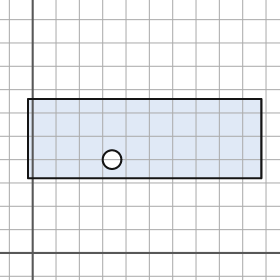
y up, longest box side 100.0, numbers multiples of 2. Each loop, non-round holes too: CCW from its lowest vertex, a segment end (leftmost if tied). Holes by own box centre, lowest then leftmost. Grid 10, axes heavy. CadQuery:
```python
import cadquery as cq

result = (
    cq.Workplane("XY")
    .moveTo(-2.0, 32.0)
    .lineTo(98.0, 32.0)
    .lineTo(98.0, 66.0)
    .lineTo(-2.0, 66.0)
    .close()
    .moveTo(34.0, 40.0)
    .circle(4.0)
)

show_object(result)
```